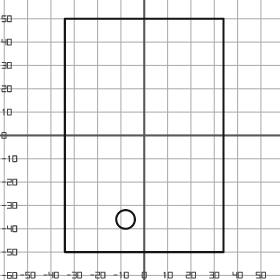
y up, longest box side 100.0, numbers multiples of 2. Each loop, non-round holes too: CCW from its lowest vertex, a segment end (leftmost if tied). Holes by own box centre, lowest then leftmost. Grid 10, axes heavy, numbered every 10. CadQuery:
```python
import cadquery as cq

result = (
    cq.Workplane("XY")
    .moveTo(-34.0, -50.0)
    .lineTo(34.0, -50.0)
    .lineTo(34.0, 50.0)
    .lineTo(-34.0, 50.0)
    .close()
    .moveTo(-8.0, -36.0)
    .circle(4.0)
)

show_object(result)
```